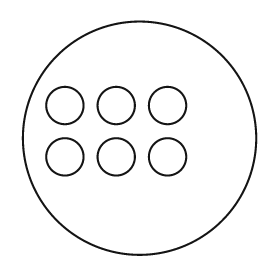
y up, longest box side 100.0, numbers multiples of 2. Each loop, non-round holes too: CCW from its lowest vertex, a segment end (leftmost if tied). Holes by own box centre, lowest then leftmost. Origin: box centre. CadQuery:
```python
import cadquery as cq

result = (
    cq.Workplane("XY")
    .moveTo(0.0, 0.0)
    .circle(50.0)
    .moveTo(-32.0, -8.0)
    .circle(8.0)
    .moveTo(-10.0, -8.0)
    .circle(8.0)
    .moveTo(12.0, -8.0)
    .circle(8.0)
    .moveTo(-32.0, 14.0)
    .circle(8.0)
    .moveTo(-10.0, 14.0)
    .circle(8.0)
    .moveTo(12.0, 14.0)
    .circle(8.0)
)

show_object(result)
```